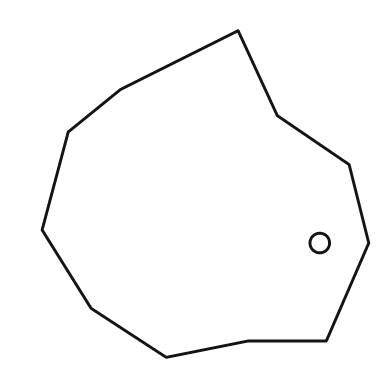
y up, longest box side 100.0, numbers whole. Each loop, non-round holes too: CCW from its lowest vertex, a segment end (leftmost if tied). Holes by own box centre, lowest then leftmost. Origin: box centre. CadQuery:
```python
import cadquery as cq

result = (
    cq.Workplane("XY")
    .moveTo(-12.0, -50.0)
    .lineTo(13.0, -45.0)
    .lineTo(37.0, -45.0)
    .lineTo(50.0, -15.0)
    .lineTo(44.0, 9.0)
    .lineTo(22.0, 24.0)
    .lineTo(10.0, 50.0)
    .lineTo(-26.0, 32.0)
    .lineTo(-42.0, 19.0)
    .lineTo(-50.0, -11.0)
    .lineTo(-35.0, -35.0)
    .close()
    .moveTo(35.0, -15.0)
    .circle(3.0)
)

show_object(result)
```